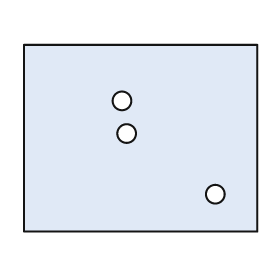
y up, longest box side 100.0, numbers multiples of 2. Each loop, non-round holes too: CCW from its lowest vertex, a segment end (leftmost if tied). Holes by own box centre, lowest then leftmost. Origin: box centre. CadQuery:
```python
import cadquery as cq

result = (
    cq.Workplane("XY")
    .moveTo(-50.0, -40.0)
    .lineTo(50.0, -40.0)
    .lineTo(50.0, 40.0)
    .lineTo(-50.0, 40.0)
    .close()
    .moveTo(32.0, -24.0)
    .circle(4.0)
    .moveTo(-6.0, 2.0)
    .circle(4.0)
    .moveTo(-8.0, 16.0)
    .circle(4.0)
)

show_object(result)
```